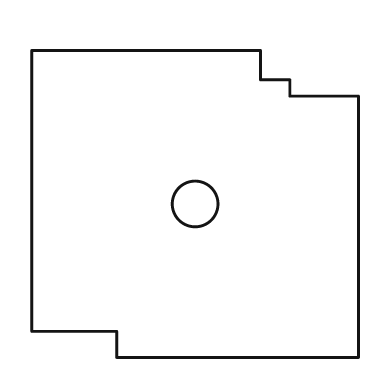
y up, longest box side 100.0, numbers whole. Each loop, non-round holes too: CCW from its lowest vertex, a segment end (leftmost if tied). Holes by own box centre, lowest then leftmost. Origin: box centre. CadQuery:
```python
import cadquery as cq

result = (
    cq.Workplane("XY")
    .moveTo(-24.0, -47.0)
    .lineTo(50.0, -47.0)
    .lineTo(50.0, 33.0)
    .lineTo(29.0, 33.0)
    .lineTo(29.0, 38.0)
    .lineTo(20.0, 38.0)
    .lineTo(20.0, 47.0)
    .lineTo(-50.0, 47.0)
    .lineTo(-50.0, -39.0)
    .lineTo(-24.0, -39.0)
    .close()
    .moveTo(0.0, 0.0)
    .circle(7.0)
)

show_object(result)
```